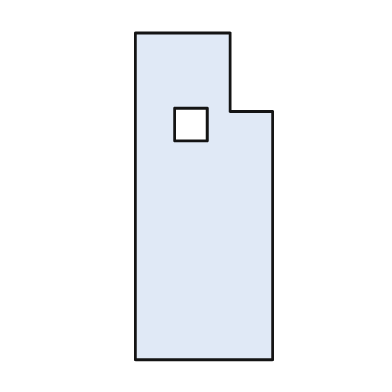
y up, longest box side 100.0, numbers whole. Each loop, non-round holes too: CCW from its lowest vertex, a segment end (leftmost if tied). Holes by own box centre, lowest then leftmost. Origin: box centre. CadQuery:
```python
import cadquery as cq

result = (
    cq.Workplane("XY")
    .moveTo(-21.0, -50.0)
    .lineTo(21.0, -50.0)
    .lineTo(21.0, 26.0)
    .lineTo(8.0, 26.0)
    .lineTo(8.0, 50.0)
    .lineTo(-21.0, 50.0)
    .close()
    .moveTo(-9.0, 17.0)
    .lineTo(1.0, 17.0)
    .lineTo(1.0, 27.0)
    .lineTo(-9.0, 27.0)
    .close()
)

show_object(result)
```